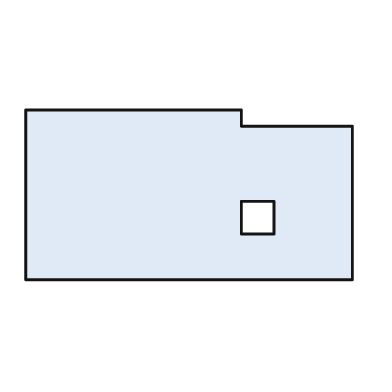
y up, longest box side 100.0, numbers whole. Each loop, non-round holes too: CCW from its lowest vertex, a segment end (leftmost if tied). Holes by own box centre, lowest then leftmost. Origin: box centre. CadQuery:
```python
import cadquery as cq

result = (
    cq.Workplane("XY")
    .moveTo(-50.0, -26.0)
    .lineTo(50.0, -26.0)
    .lineTo(50.0, 21.0)
    .lineTo(16.0, 21.0)
    .lineTo(16.0, 26.0)
    .lineTo(-50.0, 26.0)
    .close()
    .moveTo(16.0, -12.0)
    .lineTo(26.0, -12.0)
    .lineTo(26.0, -2.0)
    .lineTo(16.0, -2.0)
    .close()
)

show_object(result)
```